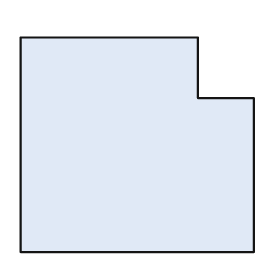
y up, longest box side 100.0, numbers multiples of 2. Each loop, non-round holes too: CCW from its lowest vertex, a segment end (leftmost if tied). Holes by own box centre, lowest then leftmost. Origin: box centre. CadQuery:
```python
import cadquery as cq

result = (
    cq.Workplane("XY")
    .moveTo(-50.0, -46.0)
    .lineTo(50.0, -46.0)
    .lineTo(50.0, 20.0)
    .lineTo(26.0, 20.0)
    .lineTo(26.0, 46.0)
    .lineTo(-50.0, 46.0)
    .close()
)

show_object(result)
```